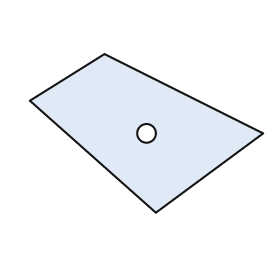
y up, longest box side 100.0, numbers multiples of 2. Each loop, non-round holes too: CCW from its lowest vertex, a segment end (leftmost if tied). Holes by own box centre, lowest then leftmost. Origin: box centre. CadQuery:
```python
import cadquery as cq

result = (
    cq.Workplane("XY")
    .moveTo(4.0, -34.0)
    .lineTo(50.0, 0.0)
    .lineTo(-18.0, 34.0)
    .lineTo(-50.0, 14.0)
    .close()
    .moveTo(0.0, 0.0)
    .circle(4.0)
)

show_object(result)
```